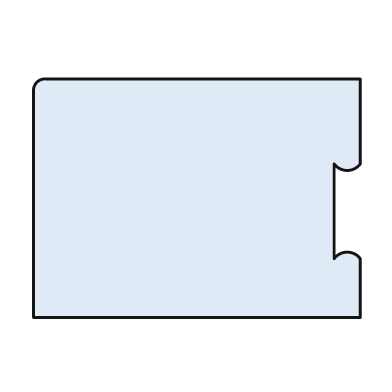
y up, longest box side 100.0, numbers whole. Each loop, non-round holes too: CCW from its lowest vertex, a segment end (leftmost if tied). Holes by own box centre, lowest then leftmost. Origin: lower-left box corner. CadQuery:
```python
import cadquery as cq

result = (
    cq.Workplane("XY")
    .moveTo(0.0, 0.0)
    .lineTo(100.0, 0.0)
    .lineTo(100.0, 18.0)
    .threePointArc((96.0, 20.0), (92.0, 18.0))
    .lineTo(92.0, 47.0)
    .threePointArc((96.0, 45.0), (100.0, 47.0))
    .lineTo(100.0, 73.0)
    .lineTo(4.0, 73.0)
    .threePointArc((1.0, 72.0), (0.0, 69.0))
    .close()
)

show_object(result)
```